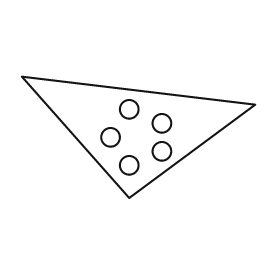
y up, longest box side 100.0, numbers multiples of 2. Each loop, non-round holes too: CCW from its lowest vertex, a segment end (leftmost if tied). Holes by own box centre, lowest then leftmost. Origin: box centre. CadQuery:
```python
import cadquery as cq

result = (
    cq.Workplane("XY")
    .moveTo(-4.0, -26.0)
    .lineTo(50.0, 14.0)
    .lineTo(-50.0, 26.0)
    .close()
    .moveTo(-4.0, -12.0)
    .circle(4.0)
    .moveTo(10.0, -6.0)
    .circle(4.0)
    .moveTo(-12.0, 0.0)
    .circle(4.0)
    .moveTo(10.0, 6.0)
    .circle(4.0)
    .moveTo(-4.0, 12.0)
    .circle(4.0)
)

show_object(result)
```